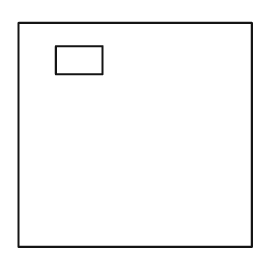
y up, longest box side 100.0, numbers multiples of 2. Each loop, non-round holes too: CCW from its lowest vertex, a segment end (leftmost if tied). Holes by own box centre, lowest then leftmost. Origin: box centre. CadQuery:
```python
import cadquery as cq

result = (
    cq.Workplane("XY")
    .moveTo(-50.0, -48.0)
    .lineTo(50.0, -48.0)
    .lineTo(50.0, 48.0)
    .lineTo(-50.0, 48.0)
    .close()
    .moveTo(-34.0, 26.0)
    .lineTo(-14.0, 26.0)
    .lineTo(-14.0, 38.0)
    .lineTo(-34.0, 38.0)
    .close()
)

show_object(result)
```